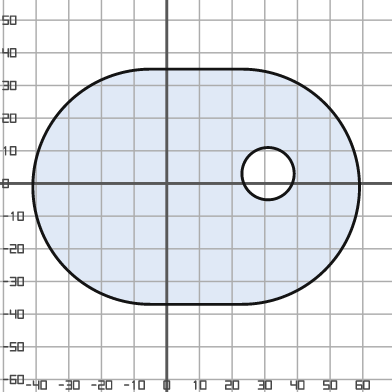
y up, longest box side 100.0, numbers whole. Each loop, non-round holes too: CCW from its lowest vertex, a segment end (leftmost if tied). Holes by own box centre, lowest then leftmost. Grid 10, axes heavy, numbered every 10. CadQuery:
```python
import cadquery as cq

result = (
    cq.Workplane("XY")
    .moveTo(-5.0, -37.0)
    .lineTo(23.0, -37.0)
    .threePointArc((59.0, -1.0), (23.0, 35.0))
    .lineTo(-5.0, 35.0)
    .threePointArc((-41.0, -1.0), (-5.0, -37.0))
    .close()
    .moveTo(31.0, 3.0)
    .circle(8.0)
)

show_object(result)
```